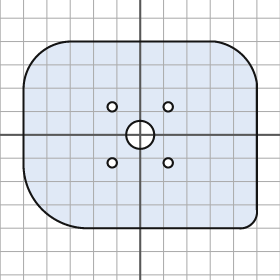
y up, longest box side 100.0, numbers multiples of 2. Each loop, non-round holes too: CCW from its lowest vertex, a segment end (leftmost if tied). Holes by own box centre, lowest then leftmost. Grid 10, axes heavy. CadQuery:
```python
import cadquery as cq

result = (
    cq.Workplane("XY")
    .moveTo(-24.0, -40.0)
    .lineTo(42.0, -40.0)
    .threePointArc((48.0, -38.0), (50.0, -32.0))
    .lineTo(50.0, 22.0)
    .threePointArc((44.0, 34.0), (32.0, 40.0))
    .lineTo(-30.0, 40.0)
    .threePointArc((-44.0, 34.0), (-50.0, 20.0))
    .lineTo(-50.0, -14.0)
    .threePointArc((-42.0, -32.0), (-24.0, -40.0))
    .close()
    .moveTo(-12.0, -12.0)
    .circle(2.0)
    .moveTo(12.0, -12.0)
    .circle(2.0)
    .moveTo(0.0, 0.0)
    .circle(6.0)
    .moveTo(-12.0, 12.0)
    .circle(2.0)
    .moveTo(12.0, 12.0)
    .circle(2.0)
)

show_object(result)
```